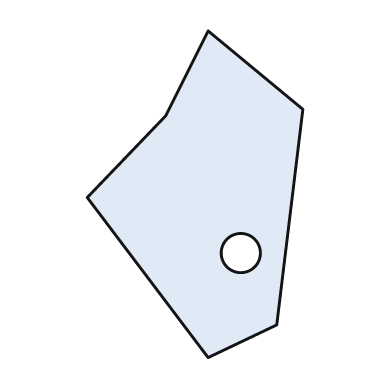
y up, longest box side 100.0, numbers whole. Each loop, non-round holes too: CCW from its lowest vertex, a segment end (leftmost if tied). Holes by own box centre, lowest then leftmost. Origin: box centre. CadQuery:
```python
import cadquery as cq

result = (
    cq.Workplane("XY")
    .moveTo(4.0, -50.0)
    .lineTo(25.0, -40.0)
    .lineTo(33.0, 26.0)
    .lineTo(4.0, 50.0)
    .lineTo(-9.0, 24.0)
    .lineTo(-33.0, -1.0)
    .close()
    .moveTo(14.0, -18.0)
    .circle(6.0)
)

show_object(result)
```